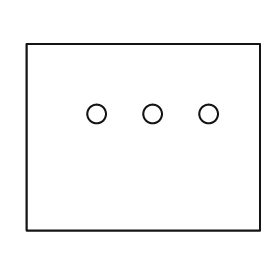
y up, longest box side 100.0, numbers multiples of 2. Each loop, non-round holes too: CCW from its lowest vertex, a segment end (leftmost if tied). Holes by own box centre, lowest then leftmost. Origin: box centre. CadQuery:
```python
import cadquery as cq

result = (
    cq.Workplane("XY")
    .moveTo(-50.0, -40.0)
    .lineTo(50.0, -40.0)
    .lineTo(50.0, 40.0)
    .lineTo(-50.0, 40.0)
    .close()
    .moveTo(-20.0, 10.0)
    .circle(4.0)
    .moveTo(4.0, 10.0)
    .circle(4.0)
    .moveTo(28.0, 10.0)
    .circle(4.0)
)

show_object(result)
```